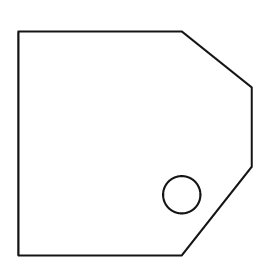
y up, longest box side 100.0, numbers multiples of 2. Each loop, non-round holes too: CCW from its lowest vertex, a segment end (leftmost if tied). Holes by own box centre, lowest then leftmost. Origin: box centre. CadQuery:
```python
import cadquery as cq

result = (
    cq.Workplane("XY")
    .moveTo(-50.0, -48.0)
    .lineTo(20.0, -48.0)
    .lineTo(50.0, -10.0)
    .lineTo(50.0, 24.0)
    .lineTo(20.0, 48.0)
    .lineTo(-50.0, 48.0)
    .close()
    .moveTo(20.0, -22.0)
    .circle(8.0)
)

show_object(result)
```